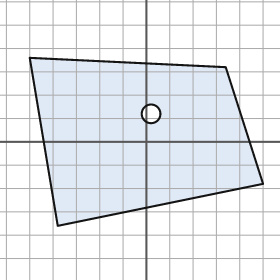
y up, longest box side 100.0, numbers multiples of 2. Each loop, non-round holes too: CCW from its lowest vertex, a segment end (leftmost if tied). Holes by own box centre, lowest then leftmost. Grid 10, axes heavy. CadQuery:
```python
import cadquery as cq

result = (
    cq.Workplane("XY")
    .moveTo(-38.0, -36.0)
    .lineTo(50.0, -18.0)
    .lineTo(34.0, 32.0)
    .lineTo(-50.0, 36.0)
    .close()
    .moveTo(2.0, 12.0)
    .circle(4.0)
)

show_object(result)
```